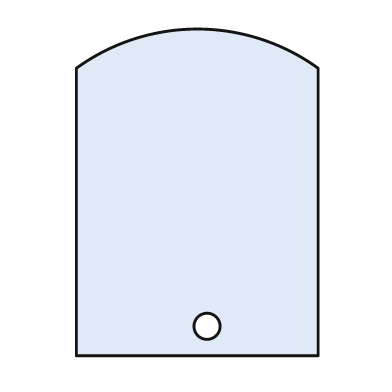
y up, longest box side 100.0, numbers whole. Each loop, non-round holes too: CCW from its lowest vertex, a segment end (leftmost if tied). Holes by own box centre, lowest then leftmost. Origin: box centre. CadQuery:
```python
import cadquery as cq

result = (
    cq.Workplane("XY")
    .moveTo(-37.0, -50.0)
    .lineTo(37.0, -50.0)
    .lineTo(37.0, 38.0)
    .threePointArc((0.0, 50.0), (-37.0, 38.0))
    .close()
    .moveTo(3.0, -41.0)
    .circle(4.0)
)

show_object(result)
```